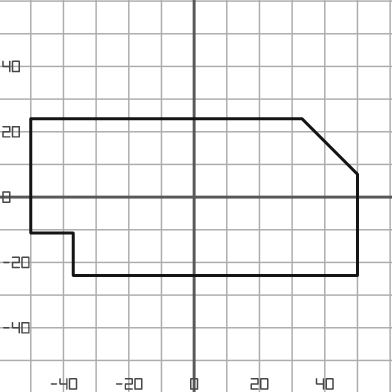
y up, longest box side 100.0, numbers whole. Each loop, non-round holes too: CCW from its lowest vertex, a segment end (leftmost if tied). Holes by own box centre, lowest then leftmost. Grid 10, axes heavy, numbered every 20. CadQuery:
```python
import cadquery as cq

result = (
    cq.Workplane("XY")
    .moveTo(-37.0, -24.0)
    .lineTo(50.0, -24.0)
    .lineTo(50.0, 7.0)
    .lineTo(33.0, 24.0)
    .lineTo(-50.0, 24.0)
    .lineTo(-50.0, -11.0)
    .lineTo(-37.0, -11.0)
    .close()
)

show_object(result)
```